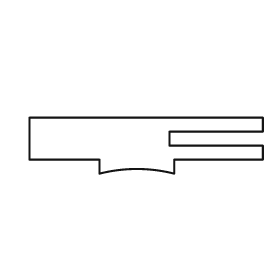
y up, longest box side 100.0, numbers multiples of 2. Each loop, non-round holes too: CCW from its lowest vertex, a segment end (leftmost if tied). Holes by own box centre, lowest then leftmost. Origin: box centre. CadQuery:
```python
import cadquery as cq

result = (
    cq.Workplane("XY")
    .moveTo(-20.0, -12.0)
    .threePointArc((-4.0, -10.0), (12.0, -12.0))
    .lineTo(12.0, -6.0)
    .lineTo(50.0, -6.0)
    .lineTo(50.0, 0.0)
    .lineTo(10.0, 0.0)
    .lineTo(10.0, 6.0)
    .lineTo(50.0, 6.0)
    .lineTo(50.0, 12.0)
    .lineTo(-50.0, 12.0)
    .lineTo(-50.0, -6.0)
    .lineTo(-20.0, -6.0)
    .close()
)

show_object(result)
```